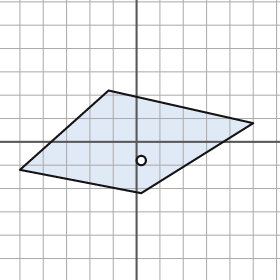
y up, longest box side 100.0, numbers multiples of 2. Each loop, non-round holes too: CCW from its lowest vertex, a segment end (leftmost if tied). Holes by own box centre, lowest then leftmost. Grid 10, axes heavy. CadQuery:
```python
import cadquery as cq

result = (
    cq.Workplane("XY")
    .moveTo(2.0, -22.0)
    .lineTo(50.0, 8.0)
    .lineTo(-12.0, 22.0)
    .lineTo(-50.0, -12.0)
    .close()
    .moveTo(2.0, -8.0)
    .circle(2.0)
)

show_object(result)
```